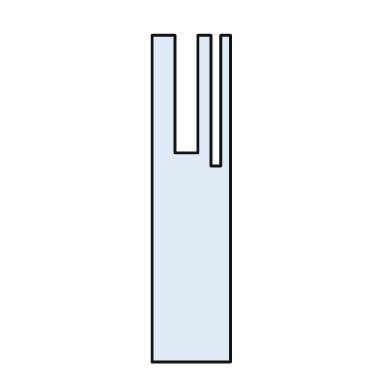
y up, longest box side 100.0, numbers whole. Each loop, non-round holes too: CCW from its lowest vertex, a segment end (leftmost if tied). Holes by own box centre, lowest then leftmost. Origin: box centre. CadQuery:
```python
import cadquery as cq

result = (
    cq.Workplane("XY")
    .moveTo(-12.0, -50.0)
    .lineTo(12.0, -50.0)
    .lineTo(12.0, 50.0)
    .lineTo(9.0, 50.0)
    .lineTo(9.0, 10.0)
    .lineTo(6.0, 10.0)
    .lineTo(6.0, 50.0)
    .lineTo(2.0, 50.0)
    .lineTo(2.0, 14.0)
    .lineTo(-5.0, 14.0)
    .lineTo(-5.0, 50.0)
    .lineTo(-12.0, 50.0)
    .close()
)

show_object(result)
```